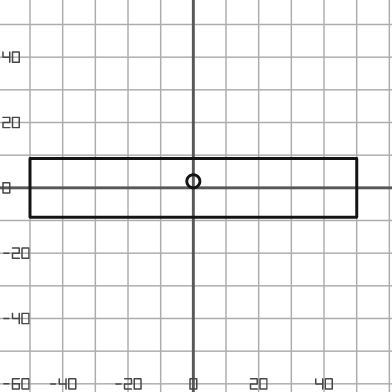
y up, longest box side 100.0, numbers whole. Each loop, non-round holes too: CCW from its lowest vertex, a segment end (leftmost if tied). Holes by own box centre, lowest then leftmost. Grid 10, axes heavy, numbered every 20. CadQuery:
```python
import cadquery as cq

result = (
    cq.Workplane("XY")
    .moveTo(-50.0, -9.0)
    .lineTo(50.0, -9.0)
    .lineTo(50.0, 9.0)
    .lineTo(-50.0, 9.0)
    .close()
    .moveTo(0.0, 2.0)
    .circle(2.0)
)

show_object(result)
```